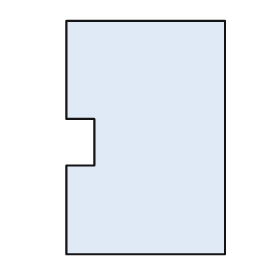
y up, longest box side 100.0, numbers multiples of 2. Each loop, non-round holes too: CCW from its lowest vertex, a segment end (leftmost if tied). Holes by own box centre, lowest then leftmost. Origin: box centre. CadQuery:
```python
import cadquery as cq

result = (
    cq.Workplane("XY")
    .moveTo(-34.0, -50.0)
    .lineTo(34.0, -50.0)
    .lineTo(34.0, 50.0)
    .lineTo(-34.0, 50.0)
    .lineTo(-34.0, 8.0)
    .lineTo(-22.0, 8.0)
    .lineTo(-22.0, -12.0)
    .lineTo(-34.0, -12.0)
    .close()
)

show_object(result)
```